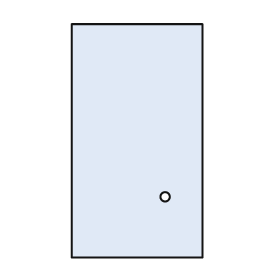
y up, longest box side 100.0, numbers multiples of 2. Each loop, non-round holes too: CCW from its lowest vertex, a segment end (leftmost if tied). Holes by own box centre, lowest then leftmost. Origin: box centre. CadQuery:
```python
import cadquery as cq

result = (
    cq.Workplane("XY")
    .moveTo(-28.0, -50.0)
    .lineTo(28.0, -50.0)
    .lineTo(28.0, 50.0)
    .lineTo(-28.0, 50.0)
    .close()
    .moveTo(12.0, -24.0)
    .circle(2.0)
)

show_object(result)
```